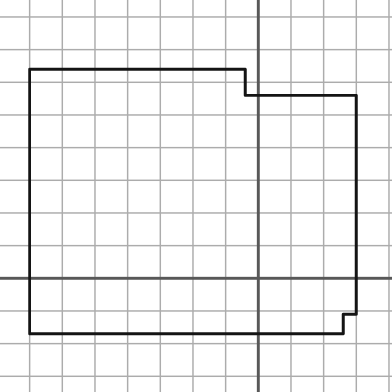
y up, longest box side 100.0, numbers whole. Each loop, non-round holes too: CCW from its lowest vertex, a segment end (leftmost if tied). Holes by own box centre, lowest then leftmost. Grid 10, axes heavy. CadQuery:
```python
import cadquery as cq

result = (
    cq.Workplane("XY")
    .moveTo(-70.0, -17.0)
    .lineTo(26.0, -17.0)
    .lineTo(26.0, -11.0)
    .lineTo(30.0, -11.0)
    .lineTo(30.0, 56.0)
    .lineTo(-4.0, 56.0)
    .lineTo(-4.0, 64.0)
    .lineTo(-70.0, 64.0)
    .close()
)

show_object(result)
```